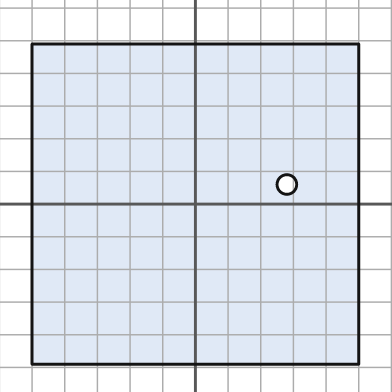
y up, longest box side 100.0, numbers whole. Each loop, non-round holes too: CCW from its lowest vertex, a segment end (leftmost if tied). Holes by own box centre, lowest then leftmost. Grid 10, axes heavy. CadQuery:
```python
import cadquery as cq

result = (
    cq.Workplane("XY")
    .moveTo(-50.0, -49.0)
    .lineTo(50.0, -49.0)
    .lineTo(50.0, 49.0)
    .lineTo(-50.0, 49.0)
    .close()
    .moveTo(28.0, 6.0)
    .circle(3.0)
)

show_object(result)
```